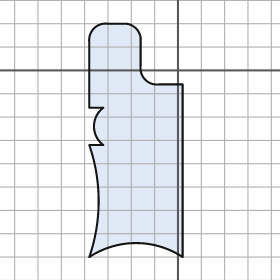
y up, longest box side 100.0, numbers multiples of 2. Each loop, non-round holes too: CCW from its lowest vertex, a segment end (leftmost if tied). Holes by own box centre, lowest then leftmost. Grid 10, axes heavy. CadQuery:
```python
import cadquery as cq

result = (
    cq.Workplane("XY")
    .moveTo(-38.0, -80.0)
    .threePointArc((-18.0, -74.0), (2.0, -80.0))
    .lineTo(2.0, -6.0)
    .lineTo(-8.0, -6.0)
    .threePointArc((-14.0, -4.0), (-16.0, 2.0))
    .lineTo(-16.0, 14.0)
    .threePointArc((-18.0, 18.0), (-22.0, 20.0))
    .lineTo(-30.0, 20.0)
    .threePointArc((-36.0, 18.0), (-38.0, 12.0))
    .lineTo(-38.0, -16.0)
    .lineTo(-32.0, -16.0)
    .threePointArc((-36.0, -24.0), (-32.0, -32.0))
    .lineTo(-38.0, -32.0)
    .threePointArc((-34.0, -56.0), (-38.0, -80.0))
    .close()
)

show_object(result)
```